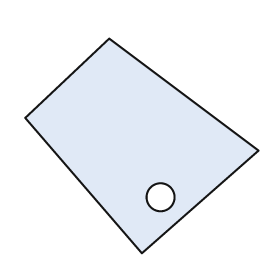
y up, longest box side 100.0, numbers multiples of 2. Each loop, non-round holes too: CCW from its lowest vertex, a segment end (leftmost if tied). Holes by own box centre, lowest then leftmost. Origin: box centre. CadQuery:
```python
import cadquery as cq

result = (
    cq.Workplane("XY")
    .moveTo(0.0, -46.0)
    .lineTo(50.0, -2.0)
    .lineTo(-14.0, 46.0)
    .lineTo(-50.0, 12.0)
    .close()
    .moveTo(8.0, -22.0)
    .circle(6.0)
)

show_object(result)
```